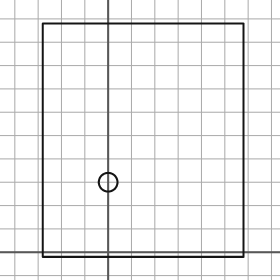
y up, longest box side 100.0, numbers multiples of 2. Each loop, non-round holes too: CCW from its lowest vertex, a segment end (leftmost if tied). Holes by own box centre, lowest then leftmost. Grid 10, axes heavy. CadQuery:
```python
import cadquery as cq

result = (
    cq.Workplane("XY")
    .moveTo(-28.0, -2.0)
    .lineTo(58.0, -2.0)
    .lineTo(58.0, 98.0)
    .lineTo(-28.0, 98.0)
    .close()
    .moveTo(0.0, 30.0)
    .circle(4.0)
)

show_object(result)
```